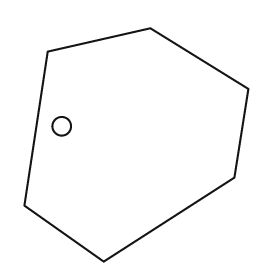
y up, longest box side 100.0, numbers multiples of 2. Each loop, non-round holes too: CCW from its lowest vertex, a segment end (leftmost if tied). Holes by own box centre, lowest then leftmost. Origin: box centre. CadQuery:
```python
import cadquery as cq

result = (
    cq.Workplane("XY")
    .moveTo(-14.0, -50.0)
    .lineTo(42.0, -14.0)
    .lineTo(48.0, 24.0)
    .lineTo(6.0, 50.0)
    .lineTo(-38.0, 40.0)
    .lineTo(-48.0, -26.0)
    .close()
    .moveTo(-32.0, 8.0)
    .circle(4.0)
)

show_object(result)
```